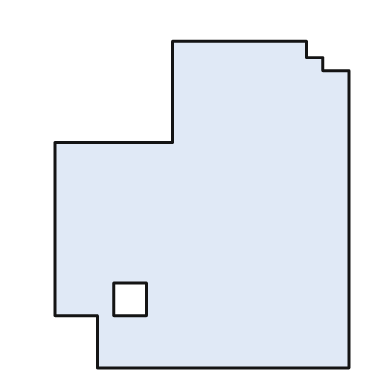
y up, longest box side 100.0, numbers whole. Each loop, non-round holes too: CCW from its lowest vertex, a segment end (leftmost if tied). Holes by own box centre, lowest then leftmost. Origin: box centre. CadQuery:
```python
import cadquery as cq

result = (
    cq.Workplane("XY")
    .moveTo(-32.0, -50.0)
    .lineTo(45.0, -50.0)
    .lineTo(45.0, 41.0)
    .lineTo(37.0, 41.0)
    .lineTo(37.0, 45.0)
    .lineTo(32.0, 45.0)
    .lineTo(32.0, 50.0)
    .lineTo(-9.0, 50.0)
    .lineTo(-9.0, 19.0)
    .lineTo(-45.0, 19.0)
    .lineTo(-45.0, -34.0)
    .lineTo(-32.0, -34.0)
    .close()
    .moveTo(-27.0, -34.0)
    .lineTo(-17.0, -34.0)
    .lineTo(-17.0, -24.0)
    .lineTo(-27.0, -24.0)
    .close()
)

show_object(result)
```